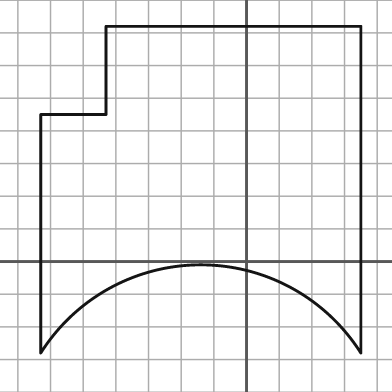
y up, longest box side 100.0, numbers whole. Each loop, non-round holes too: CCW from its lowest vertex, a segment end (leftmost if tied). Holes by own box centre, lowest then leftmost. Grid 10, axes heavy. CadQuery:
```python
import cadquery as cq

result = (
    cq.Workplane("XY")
    .moveTo(-63.0, -28.0)
    .threePointArc((-14.0, -1.0), (35.0, -28.0))
    .lineTo(35.0, 72.0)
    .lineTo(-43.0, 72.0)
    .lineTo(-43.0, 45.0)
    .lineTo(-63.0, 45.0)
    .close()
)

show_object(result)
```